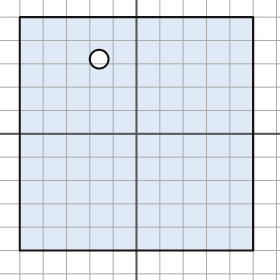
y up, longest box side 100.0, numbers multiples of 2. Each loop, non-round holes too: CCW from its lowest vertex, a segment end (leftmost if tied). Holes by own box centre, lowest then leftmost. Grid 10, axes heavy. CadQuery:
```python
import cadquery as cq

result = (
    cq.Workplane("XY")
    .moveTo(-50.0, -50.0)
    .lineTo(50.0, -50.0)
    .lineTo(50.0, 50.0)
    .lineTo(-50.0, 50.0)
    .close()
    .moveTo(-16.0, 32.0)
    .circle(4.0)
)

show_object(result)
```